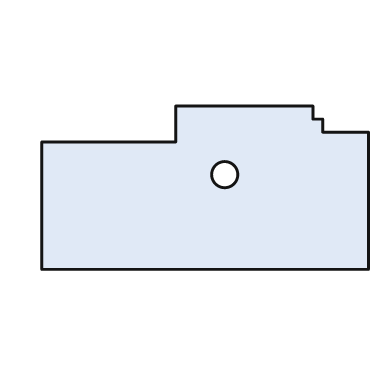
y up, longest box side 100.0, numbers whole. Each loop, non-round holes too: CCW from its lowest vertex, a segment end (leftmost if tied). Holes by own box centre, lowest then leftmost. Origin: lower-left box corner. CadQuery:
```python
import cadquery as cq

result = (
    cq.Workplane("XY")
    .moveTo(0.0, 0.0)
    .lineTo(100.0, 0.0)
    .lineTo(100.0, 42.0)
    .lineTo(86.0, 42.0)
    .lineTo(86.0, 46.0)
    .lineTo(83.0, 46.0)
    .lineTo(83.0, 50.0)
    .lineTo(41.0, 50.0)
    .lineTo(41.0, 39.0)
    .lineTo(0.0, 39.0)
    .close()
    .moveTo(56.0, 29.0)
    .circle(4.0)
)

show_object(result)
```